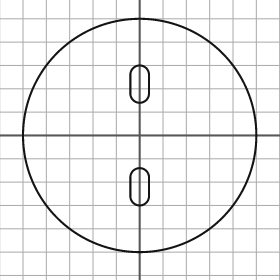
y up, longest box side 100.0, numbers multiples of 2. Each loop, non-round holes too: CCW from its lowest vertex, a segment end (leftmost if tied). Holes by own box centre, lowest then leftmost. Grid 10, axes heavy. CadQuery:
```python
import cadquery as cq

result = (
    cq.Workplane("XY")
    .moveTo(0.0, 0.0)
    .circle(50.0)
    .moveTo(-4.0, -26.0)
    .threePointArc((0.0, -30.0), (4.0, -26.0))
    .lineTo(4.0, -18.0)
    .threePointArc((0.0, -14.0), (-4.0, -18.0))
    .close()
    .moveTo(-4.0, 18.0)
    .threePointArc((0.0, 14.0), (4.0, 18.0))
    .lineTo(4.0, 26.0)
    .threePointArc((0.0, 30.0), (-4.0, 26.0))
    .close()
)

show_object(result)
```